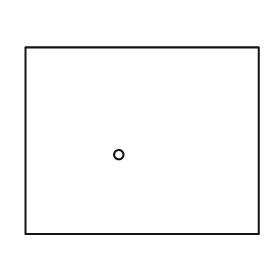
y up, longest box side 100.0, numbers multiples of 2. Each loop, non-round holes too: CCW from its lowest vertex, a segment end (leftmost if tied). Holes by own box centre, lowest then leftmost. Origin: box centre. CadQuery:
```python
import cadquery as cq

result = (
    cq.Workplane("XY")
    .moveTo(-50.0, -40.0)
    .lineTo(50.0, -40.0)
    .lineTo(50.0, 40.0)
    .lineTo(-50.0, 40.0)
    .close()
    .moveTo(-10.0, -6.0)
    .circle(2.0)
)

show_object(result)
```